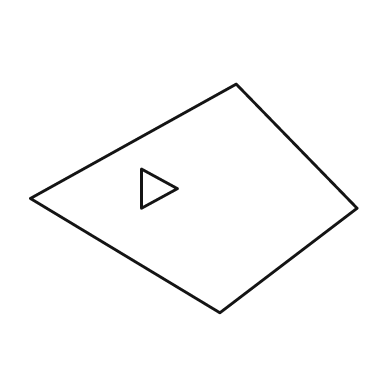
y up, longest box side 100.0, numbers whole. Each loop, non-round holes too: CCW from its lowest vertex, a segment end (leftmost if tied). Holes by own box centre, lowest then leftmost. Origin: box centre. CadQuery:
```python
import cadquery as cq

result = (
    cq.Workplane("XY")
    .moveTo(8.0, -35.0)
    .lineTo(50.0, -3.0)
    .lineTo(13.0, 35.0)
    .lineTo(-50.0, 0.0)
    .close()
    .moveTo(-16.0, -3.0)
    .lineTo(-5.0, 3.0)
    .lineTo(-16.0, 9.0)
    .close()
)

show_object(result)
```